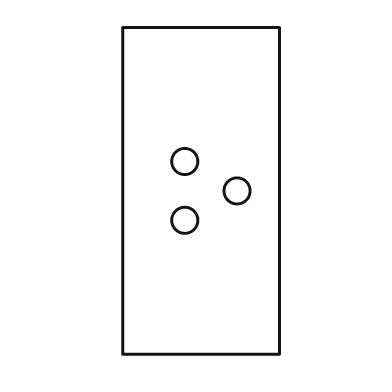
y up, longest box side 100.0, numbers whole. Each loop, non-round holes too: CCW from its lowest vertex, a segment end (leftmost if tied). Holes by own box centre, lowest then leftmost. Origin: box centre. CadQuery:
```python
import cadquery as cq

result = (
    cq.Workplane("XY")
    .moveTo(-24.0, -50.0)
    .lineTo(24.0, -50.0)
    .lineTo(24.0, 50.0)
    .lineTo(-24.0, 50.0)
    .close()
    .moveTo(-5.0, -9.0)
    .circle(4.0)
    .moveTo(11.0, 0.0)
    .circle(4.0)
    .moveTo(-5.0, 9.0)
    .circle(4.0)
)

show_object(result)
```